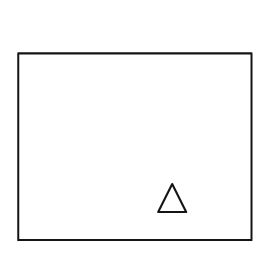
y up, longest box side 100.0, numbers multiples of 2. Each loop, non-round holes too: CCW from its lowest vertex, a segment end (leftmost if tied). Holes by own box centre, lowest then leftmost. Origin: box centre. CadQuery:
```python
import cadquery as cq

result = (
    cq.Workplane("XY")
    .moveTo(-50.0, -40.0)
    .lineTo(50.0, -40.0)
    .lineTo(50.0, 40.0)
    .lineTo(-50.0, 40.0)
    .close()
    .moveTo(10.0, -28.0)
    .lineTo(22.0, -28.0)
    .lineTo(16.0, -16.0)
    .close()
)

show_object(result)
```